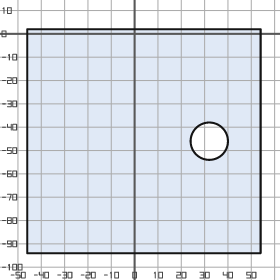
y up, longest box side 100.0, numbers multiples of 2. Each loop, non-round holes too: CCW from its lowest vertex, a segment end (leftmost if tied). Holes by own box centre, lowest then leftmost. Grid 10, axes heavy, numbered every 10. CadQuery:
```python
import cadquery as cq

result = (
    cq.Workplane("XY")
    .moveTo(-46.0, -94.0)
    .lineTo(54.0, -94.0)
    .lineTo(54.0, 2.0)
    .lineTo(-46.0, 2.0)
    .close()
    .moveTo(32.0, -46.0)
    .circle(8.0)
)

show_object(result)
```